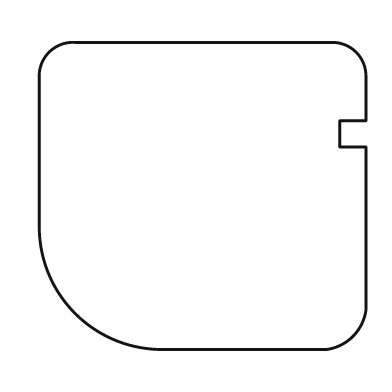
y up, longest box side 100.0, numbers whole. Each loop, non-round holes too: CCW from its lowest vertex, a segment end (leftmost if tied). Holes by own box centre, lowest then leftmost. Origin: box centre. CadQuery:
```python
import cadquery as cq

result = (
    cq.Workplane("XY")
    .moveTo(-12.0, -47.0)
    .lineTo(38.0, -47.0)
    .threePointArc((46.0, -43.0), (50.0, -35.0))
    .lineTo(50.0, 15.0)
    .lineTo(42.0, 15.0)
    .lineTo(42.0, 23.0)
    .lineTo(50.0, 23.0)
    .lineTo(50.0, 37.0)
    .threePointArc((47.0, 44.0), (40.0, 47.0))
    .lineTo(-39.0, 47.0)
    .threePointArc((-47.0, 44.0), (-50.0, 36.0))
    .lineTo(-50.0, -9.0)
    .threePointArc((-39.0, -36.0), (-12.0, -47.0))
    .close()
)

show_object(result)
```